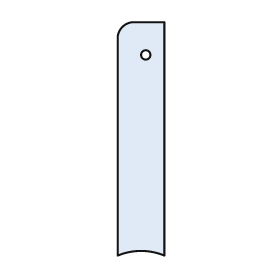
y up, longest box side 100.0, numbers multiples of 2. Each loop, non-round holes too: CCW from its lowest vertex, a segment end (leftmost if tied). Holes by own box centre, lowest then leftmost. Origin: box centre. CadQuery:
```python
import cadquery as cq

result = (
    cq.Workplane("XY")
    .moveTo(-10.0, -50.0)
    .threePointArc((0.0, -48.0), (10.0, -50.0))
    .lineTo(10.0, 50.0)
    .lineTo(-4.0, 50.0)
    .threePointArc((-8.0, 48.0), (-10.0, 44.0))
    .close()
    .moveTo(2.0, 36.0)
    .circle(2.0)
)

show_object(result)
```